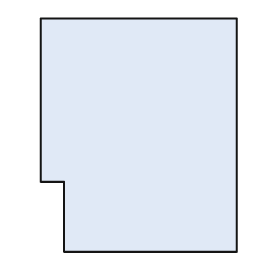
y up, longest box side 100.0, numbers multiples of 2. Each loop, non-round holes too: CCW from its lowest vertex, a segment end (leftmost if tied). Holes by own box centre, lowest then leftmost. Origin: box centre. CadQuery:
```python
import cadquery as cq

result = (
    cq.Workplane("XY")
    .moveTo(-32.0, -50.0)
    .lineTo(42.0, -50.0)
    .lineTo(42.0, 50.0)
    .lineTo(-42.0, 50.0)
    .lineTo(-42.0, -20.0)
    .lineTo(-32.0, -20.0)
    .close()
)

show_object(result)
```